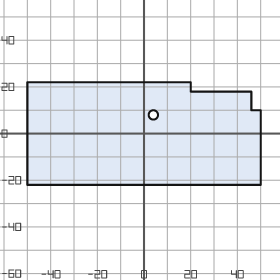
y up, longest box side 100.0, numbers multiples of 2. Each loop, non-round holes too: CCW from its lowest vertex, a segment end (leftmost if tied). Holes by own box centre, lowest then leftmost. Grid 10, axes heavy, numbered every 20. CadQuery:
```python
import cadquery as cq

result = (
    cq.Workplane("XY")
    .moveTo(-50.0, -22.0)
    .lineTo(50.0, -22.0)
    .lineTo(50.0, 10.0)
    .lineTo(46.0, 10.0)
    .lineTo(46.0, 18.0)
    .lineTo(20.0, 18.0)
    .lineTo(20.0, 22.0)
    .lineTo(-50.0, 22.0)
    .close()
    .moveTo(4.0, 8.0)
    .circle(2.0)
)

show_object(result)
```